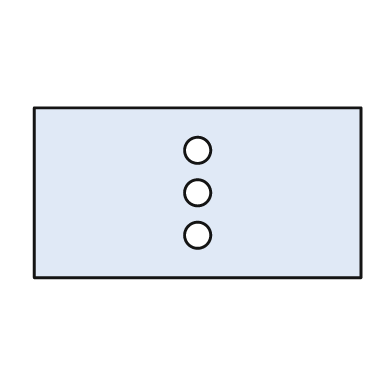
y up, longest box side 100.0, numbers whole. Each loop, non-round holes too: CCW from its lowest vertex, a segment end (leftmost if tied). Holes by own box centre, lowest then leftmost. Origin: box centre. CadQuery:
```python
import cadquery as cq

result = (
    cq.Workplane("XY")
    .moveTo(-50.0, -26.0)
    .lineTo(50.0, -26.0)
    .lineTo(50.0, 26.0)
    .lineTo(-50.0, 26.0)
    .close()
    .moveTo(0.0, -13.0)
    .circle(4.0)
    .moveTo(0.0, 0.0)
    .circle(4.0)
    .moveTo(0.0, 13.0)
    .circle(4.0)
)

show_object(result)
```